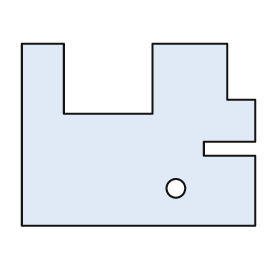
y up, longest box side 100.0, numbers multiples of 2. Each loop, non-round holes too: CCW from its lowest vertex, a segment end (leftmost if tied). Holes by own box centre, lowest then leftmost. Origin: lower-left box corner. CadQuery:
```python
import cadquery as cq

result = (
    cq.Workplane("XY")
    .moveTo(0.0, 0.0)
    .lineTo(100.0, 0.0)
    .lineTo(100.0, 30.0)
    .lineTo(78.0, 30.0)
    .lineTo(78.0, 36.0)
    .lineTo(100.0, 36.0)
    .lineTo(100.0, 54.0)
    .lineTo(88.0, 54.0)
    .lineTo(88.0, 78.0)
    .lineTo(56.0, 78.0)
    .lineTo(56.0, 48.0)
    .lineTo(18.0, 48.0)
    .lineTo(18.0, 78.0)
    .lineTo(0.0, 78.0)
    .close()
    .moveTo(66.0, 16.0)
    .circle(4.0)
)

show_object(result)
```